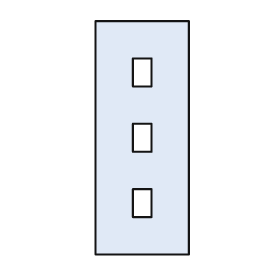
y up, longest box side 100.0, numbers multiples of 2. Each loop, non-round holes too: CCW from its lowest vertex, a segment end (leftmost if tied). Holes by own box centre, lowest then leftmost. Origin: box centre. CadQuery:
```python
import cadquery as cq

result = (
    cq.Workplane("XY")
    .moveTo(-20.0, -50.0)
    .lineTo(20.0, -50.0)
    .lineTo(20.0, 50.0)
    .lineTo(-20.0, 50.0)
    .close()
    .moveTo(-4.0, -34.0)
    .lineTo(4.0, -34.0)
    .lineTo(4.0, -22.0)
    .lineTo(-4.0, -22.0)
    .close()
    .moveTo(-4.0, -6.0)
    .lineTo(4.0, -6.0)
    .lineTo(4.0, 6.0)
    .lineTo(-4.0, 6.0)
    .close()
    .moveTo(-4.0, 22.0)
    .lineTo(4.0, 22.0)
    .lineTo(4.0, 34.0)
    .lineTo(-4.0, 34.0)
    .close()
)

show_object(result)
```